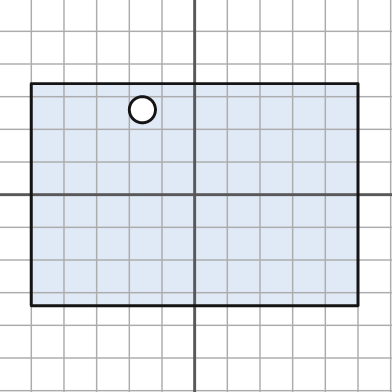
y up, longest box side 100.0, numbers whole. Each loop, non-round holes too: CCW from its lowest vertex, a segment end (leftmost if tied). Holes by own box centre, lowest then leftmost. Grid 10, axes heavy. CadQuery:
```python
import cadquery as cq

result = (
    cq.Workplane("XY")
    .moveTo(-50.0, -34.0)
    .lineTo(50.0, -34.0)
    .lineTo(50.0, 34.0)
    .lineTo(-50.0, 34.0)
    .close()
    .moveTo(-16.0, 26.0)
    .circle(4.0)
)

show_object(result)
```